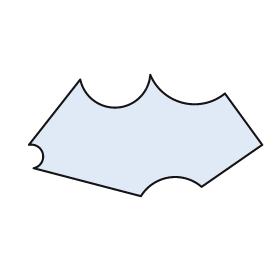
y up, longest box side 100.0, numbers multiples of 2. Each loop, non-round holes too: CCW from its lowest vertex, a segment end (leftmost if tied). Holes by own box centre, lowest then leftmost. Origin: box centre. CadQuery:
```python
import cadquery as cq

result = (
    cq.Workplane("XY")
    .moveTo(-2.0, -26.0)
    .threePointArc((10.0, -18.0), (24.0, -22.0))
    .lineTo(50.0, -4.0)
    .lineTo(34.0, 18.0)
    .threePointArc((16.0, 14.0), (2.0, 26.0))
    .threePointArc((-12.0, 12.0), (-28.0, 24.0))
    .lineTo(-50.0, -4.0)
    .threePointArc((-44.0, -8.0), (-48.0, -14.0))
    .close()
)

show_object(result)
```